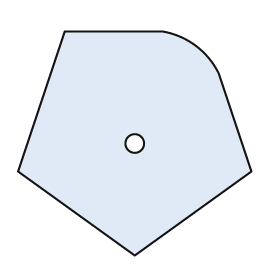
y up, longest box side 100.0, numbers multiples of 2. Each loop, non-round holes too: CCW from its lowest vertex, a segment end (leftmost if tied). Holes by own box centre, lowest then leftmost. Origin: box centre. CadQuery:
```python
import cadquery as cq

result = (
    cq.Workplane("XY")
    .moveTo(0.0, -48.0)
    .lineTo(50.0, -12.0)
    .lineTo(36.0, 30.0)
    .threePointArc((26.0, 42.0), (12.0, 48.0))
    .lineTo(-30.0, 48.0)
    .lineTo(-50.0, -12.0)
    .close()
    .moveTo(0.0, 0.0)
    .circle(4.0)
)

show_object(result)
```